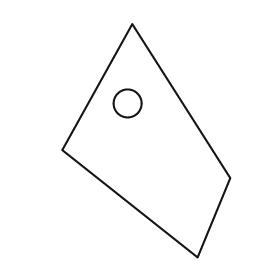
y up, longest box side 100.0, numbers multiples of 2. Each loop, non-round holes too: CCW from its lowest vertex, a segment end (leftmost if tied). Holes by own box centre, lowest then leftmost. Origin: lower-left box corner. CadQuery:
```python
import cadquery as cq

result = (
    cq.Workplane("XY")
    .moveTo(58.0, 0.0)
    .lineTo(72.0, 34.0)
    .lineTo(30.0, 100.0)
    .lineTo(0.0, 46.0)
    .close()
    .moveTo(28.0, 66.0)
    .circle(6.0)
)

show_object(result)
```